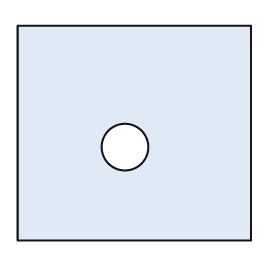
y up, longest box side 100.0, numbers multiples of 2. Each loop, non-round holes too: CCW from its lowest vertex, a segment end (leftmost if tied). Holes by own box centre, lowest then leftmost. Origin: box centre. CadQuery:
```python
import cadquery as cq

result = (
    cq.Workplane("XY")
    .moveTo(-50.0, -46.0)
    .lineTo(50.0, -46.0)
    .lineTo(50.0, 46.0)
    .lineTo(-50.0, 46.0)
    .close()
    .moveTo(-4.0, -6.0)
    .circle(10.0)
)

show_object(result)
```